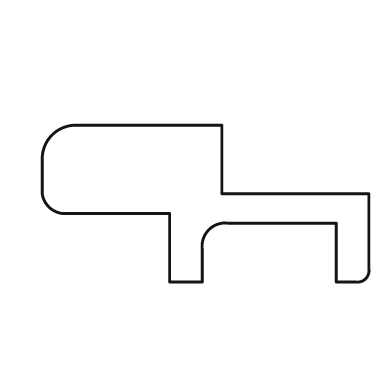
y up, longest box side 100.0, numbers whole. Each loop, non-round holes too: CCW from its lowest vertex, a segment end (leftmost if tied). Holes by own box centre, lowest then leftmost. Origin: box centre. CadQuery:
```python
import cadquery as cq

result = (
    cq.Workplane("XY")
    .moveTo(-11.0, -24.0)
    .lineTo(-1.0, -24.0)
    .lineTo(-1.0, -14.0)
    .threePointArc((1.0, -8.0), (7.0, -6.0))
    .lineTo(40.0, -6.0)
    .lineTo(40.0, -24.0)
    .lineTo(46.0, -24.0)
    .threePointArc((49.0, -23.0), (50.0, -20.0))
    .lineTo(50.0, 3.0)
    .lineTo(5.0, 3.0)
    .lineTo(5.0, 24.0)
    .lineTo(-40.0, 24.0)
    .threePointArc((-47.0, 21.0), (-50.0, 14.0))
    .lineTo(-50.0, 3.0)
    .threePointArc((-48.0, -1.0), (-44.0, -3.0))
    .lineTo(-11.0, -3.0)
    .close()
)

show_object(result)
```